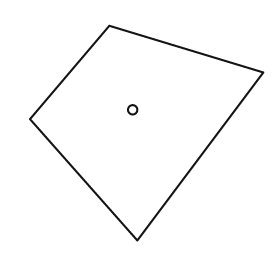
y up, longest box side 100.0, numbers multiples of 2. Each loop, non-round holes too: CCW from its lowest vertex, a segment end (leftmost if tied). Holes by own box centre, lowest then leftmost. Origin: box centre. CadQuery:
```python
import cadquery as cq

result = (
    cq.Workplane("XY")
    .moveTo(-4.0, -46.0)
    .lineTo(50.0, 26.0)
    .lineTo(-16.0, 46.0)
    .lineTo(-50.0, 6.0)
    .close()
    .moveTo(-6.0, 10.0)
    .circle(2.0)
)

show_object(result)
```